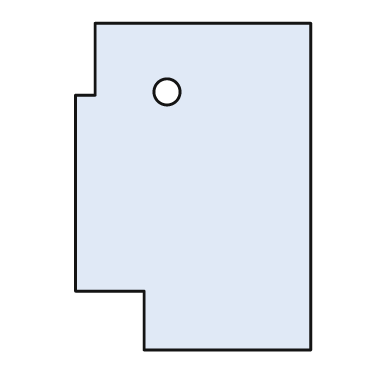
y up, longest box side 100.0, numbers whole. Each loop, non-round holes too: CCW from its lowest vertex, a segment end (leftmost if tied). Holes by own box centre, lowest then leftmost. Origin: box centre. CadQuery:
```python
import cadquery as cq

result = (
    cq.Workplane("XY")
    .moveTo(-15.0, -50.0)
    .lineTo(36.0, -50.0)
    .lineTo(36.0, 50.0)
    .lineTo(-30.0, 50.0)
    .lineTo(-30.0, 28.0)
    .lineTo(-36.0, 28.0)
    .lineTo(-36.0, -32.0)
    .lineTo(-15.0, -32.0)
    .close()
    .moveTo(-8.0, 29.0)
    .circle(4.0)
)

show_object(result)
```